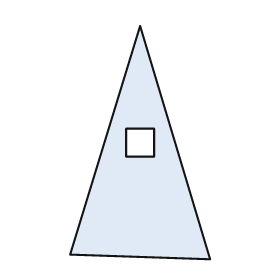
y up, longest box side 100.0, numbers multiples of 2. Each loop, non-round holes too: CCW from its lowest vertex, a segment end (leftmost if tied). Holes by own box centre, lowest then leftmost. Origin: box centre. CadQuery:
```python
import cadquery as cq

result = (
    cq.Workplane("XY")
    .moveTo(30.0, -50.0)
    .lineTo(0.0, 50.0)
    .lineTo(-30.0, -48.0)
    .close()
    .moveTo(-6.0, -6.0)
    .lineTo(6.0, -6.0)
    .lineTo(6.0, 6.0)
    .lineTo(-6.0, 6.0)
    .close()
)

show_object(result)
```